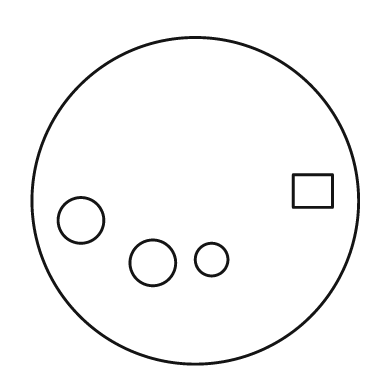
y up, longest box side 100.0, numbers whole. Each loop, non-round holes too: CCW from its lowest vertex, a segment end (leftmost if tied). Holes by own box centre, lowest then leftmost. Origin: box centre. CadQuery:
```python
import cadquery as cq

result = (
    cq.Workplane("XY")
    .moveTo(0.0, 0.0)
    .circle(50.0)
    .moveTo(-13.0, -19.0)
    .circle(7.0)
    .moveTo(5.0, -18.0)
    .circle(5.0)
    .moveTo(-35.0, -6.0)
    .circle(7.0)
    .moveTo(30.0, -2.0)
    .lineTo(42.0, -2.0)
    .lineTo(42.0, 8.0)
    .lineTo(30.0, 8.0)
    .close()
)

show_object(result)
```